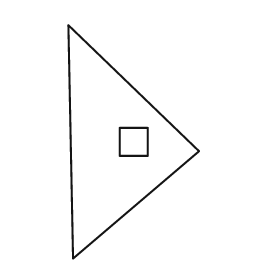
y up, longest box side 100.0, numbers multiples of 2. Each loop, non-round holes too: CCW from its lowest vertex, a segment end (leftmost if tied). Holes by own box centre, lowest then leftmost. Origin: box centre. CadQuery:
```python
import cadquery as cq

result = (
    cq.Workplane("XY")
    .moveTo(-26.0, -50.0)
    .lineTo(28.0, -4.0)
    .lineTo(-28.0, 50.0)
    .close()
    .moveTo(-6.0, -6.0)
    .lineTo(6.0, -6.0)
    .lineTo(6.0, 6.0)
    .lineTo(-6.0, 6.0)
    .close()
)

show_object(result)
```